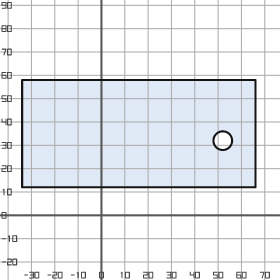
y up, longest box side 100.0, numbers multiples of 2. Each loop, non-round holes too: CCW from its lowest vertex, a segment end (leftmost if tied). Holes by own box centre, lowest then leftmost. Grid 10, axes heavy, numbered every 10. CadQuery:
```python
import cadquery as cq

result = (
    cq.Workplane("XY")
    .moveTo(-34.0, 12.0)
    .lineTo(66.0, 12.0)
    .lineTo(66.0, 58.0)
    .lineTo(-34.0, 58.0)
    .close()
    .moveTo(52.0, 32.0)
    .circle(4.0)
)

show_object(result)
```